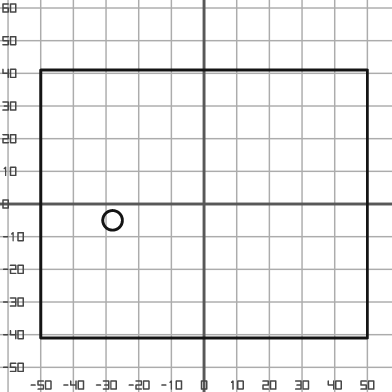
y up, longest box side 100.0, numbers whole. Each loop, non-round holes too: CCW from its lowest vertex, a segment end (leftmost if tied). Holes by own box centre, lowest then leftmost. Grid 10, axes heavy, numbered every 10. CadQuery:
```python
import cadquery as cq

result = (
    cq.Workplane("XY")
    .moveTo(-50.0, -41.0)
    .lineTo(50.0, -41.0)
    .lineTo(50.0, 41.0)
    .lineTo(-50.0, 41.0)
    .close()
    .moveTo(-28.0, -5.0)
    .circle(3.0)
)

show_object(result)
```